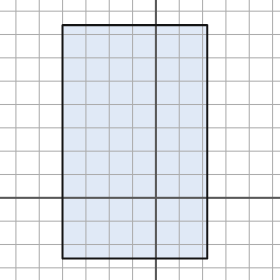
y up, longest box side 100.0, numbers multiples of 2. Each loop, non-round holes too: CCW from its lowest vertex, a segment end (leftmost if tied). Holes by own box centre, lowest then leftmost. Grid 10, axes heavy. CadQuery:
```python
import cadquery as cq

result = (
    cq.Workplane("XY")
    .moveTo(-40.0, -26.0)
    .lineTo(22.0, -26.0)
    .lineTo(22.0, 74.0)
    .lineTo(-40.0, 74.0)
    .close()
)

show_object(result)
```